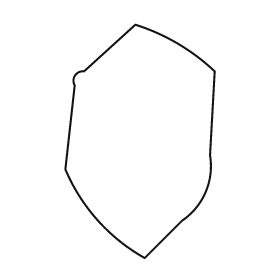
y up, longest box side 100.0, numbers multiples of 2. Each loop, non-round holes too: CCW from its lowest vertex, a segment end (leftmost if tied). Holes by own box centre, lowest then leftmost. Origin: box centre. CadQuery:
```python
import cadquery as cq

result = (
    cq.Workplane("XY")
    .moveTo(2.0, -50.0)
    .lineTo(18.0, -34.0)
    .threePointArc((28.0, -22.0), (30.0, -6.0))
    .lineTo(32.0, 30.0)
    .threePointArc((16.0, 42.0), (-2.0, 50.0))
    .lineTo(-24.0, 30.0)
    .threePointArc((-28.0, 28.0), (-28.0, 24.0))
    .lineTo(-32.0, -12.0)
    .threePointArc((-18.0, -34.0), (2.0, -50.0))
    .close()
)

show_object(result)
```